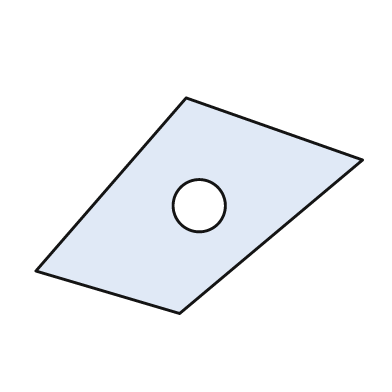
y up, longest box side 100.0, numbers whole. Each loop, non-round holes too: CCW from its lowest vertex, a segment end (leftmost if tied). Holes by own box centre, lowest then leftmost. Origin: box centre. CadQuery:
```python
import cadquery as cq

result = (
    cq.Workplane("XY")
    .moveTo(-6.0, -33.0)
    .lineTo(50.0, 14.0)
    .lineTo(-4.0, 33.0)
    .lineTo(-50.0, -20.0)
    .close()
    .moveTo(0.0, 0.0)
    .circle(8.0)
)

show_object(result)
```